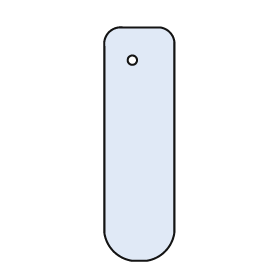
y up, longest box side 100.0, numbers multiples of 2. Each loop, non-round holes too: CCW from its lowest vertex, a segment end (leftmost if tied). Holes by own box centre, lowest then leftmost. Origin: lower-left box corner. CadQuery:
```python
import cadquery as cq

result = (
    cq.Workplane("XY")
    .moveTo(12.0, 0.0)
    .lineTo(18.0, 0.0)
    .threePointArc((26.0, 4.0), (30.0, 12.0))
    .lineTo(30.0, 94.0)
    .threePointArc((28.0, 98.0), (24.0, 100.0))
    .lineTo(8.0, 100.0)
    .threePointArc((2.0, 98.0), (0.0, 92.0))
    .lineTo(0.0, 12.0)
    .threePointArc((4.0, 4.0), (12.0, 0.0))
    .close()
    .moveTo(12.0, 86.0)
    .circle(2.0)
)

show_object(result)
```